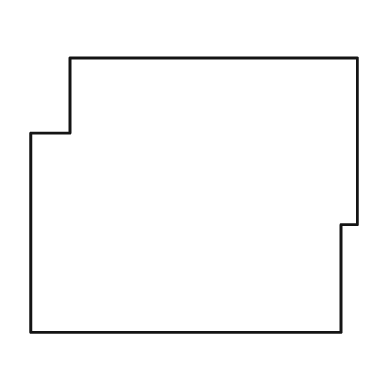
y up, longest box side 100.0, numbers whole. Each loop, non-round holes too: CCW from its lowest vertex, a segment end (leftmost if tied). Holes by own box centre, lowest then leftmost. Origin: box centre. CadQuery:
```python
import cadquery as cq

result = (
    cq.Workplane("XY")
    .moveTo(-50.0, -42.0)
    .lineTo(45.0, -42.0)
    .lineTo(45.0, -9.0)
    .lineTo(50.0, -9.0)
    .lineTo(50.0, 42.0)
    .lineTo(-38.0, 42.0)
    .lineTo(-38.0, 19.0)
    .lineTo(-50.0, 19.0)
    .close()
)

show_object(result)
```